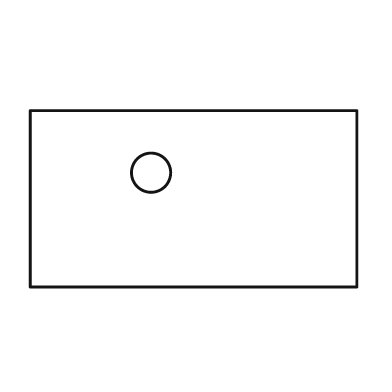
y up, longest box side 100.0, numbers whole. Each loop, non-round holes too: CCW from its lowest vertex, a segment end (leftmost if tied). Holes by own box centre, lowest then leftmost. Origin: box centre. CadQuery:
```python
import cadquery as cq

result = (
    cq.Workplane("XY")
    .moveTo(-50.0, -27.0)
    .lineTo(50.0, -27.0)
    .lineTo(50.0, 27.0)
    .lineTo(-50.0, 27.0)
    .close()
    .moveTo(-13.0, 8.0)
    .circle(6.0)
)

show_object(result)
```